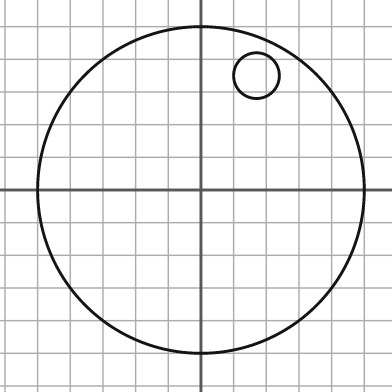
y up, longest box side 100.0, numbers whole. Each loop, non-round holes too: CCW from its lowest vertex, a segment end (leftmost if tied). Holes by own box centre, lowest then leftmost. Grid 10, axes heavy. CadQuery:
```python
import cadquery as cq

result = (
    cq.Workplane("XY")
    .moveTo(0.0, 0.0)
    .circle(50.0)
    .moveTo(17.0, 35.0)
    .circle(7.0)
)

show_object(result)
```